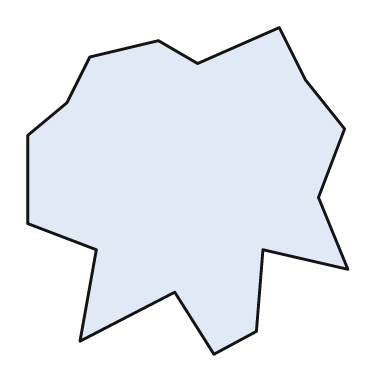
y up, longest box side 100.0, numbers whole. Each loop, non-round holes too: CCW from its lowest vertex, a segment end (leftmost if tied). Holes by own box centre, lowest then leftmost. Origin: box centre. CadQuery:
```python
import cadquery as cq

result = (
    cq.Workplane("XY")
    .moveTo(8.0, -50.0)
    .lineTo(21.0, -43.0)
    .lineTo(23.0, -18.0)
    .lineTo(49.0, -24.0)
    .lineTo(40.0, -2.0)
    .lineTo(48.0, 19.0)
    .lineTo(36.0, 34.0)
    .lineTo(28.0, 50.0)
    .lineTo(3.0, 39.0)
    .lineTo(-9.0, 46.0)
    .lineTo(-30.0, 41.0)
    .lineTo(-37.0, 27.0)
    .lineTo(-49.0, 17.0)
    .lineTo(-49.0, -10.0)
    .lineTo(-28.0, -18.0)
    .lineTo(-33.0, -46.0)
    .lineTo(-4.0, -31.0)
    .close()
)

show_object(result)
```